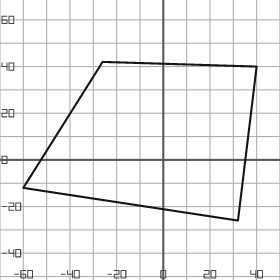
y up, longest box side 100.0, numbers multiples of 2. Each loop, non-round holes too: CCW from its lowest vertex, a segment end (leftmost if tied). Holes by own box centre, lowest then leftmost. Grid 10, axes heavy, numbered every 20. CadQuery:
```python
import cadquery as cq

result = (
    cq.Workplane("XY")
    .moveTo(32.0, -26.0)
    .lineTo(40.0, 40.0)
    .lineTo(-26.0, 42.0)
    .lineTo(-60.0, -12.0)
    .close()
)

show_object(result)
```